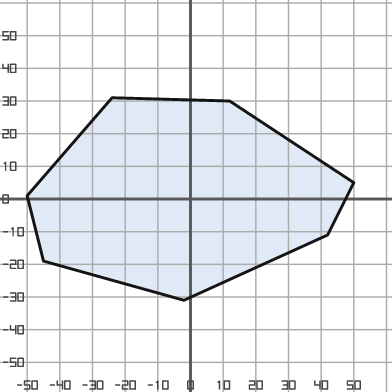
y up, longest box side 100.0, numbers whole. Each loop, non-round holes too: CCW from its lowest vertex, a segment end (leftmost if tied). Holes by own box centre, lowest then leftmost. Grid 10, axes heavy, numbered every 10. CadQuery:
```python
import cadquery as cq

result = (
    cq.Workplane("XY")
    .moveTo(-2.0, -31.0)
    .lineTo(42.0, -11.0)
    .lineTo(50.0, 5.0)
    .lineTo(12.0, 30.0)
    .lineTo(-24.0, 31.0)
    .lineTo(-50.0, 1.0)
    .lineTo(-45.0, -19.0)
    .close()
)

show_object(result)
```